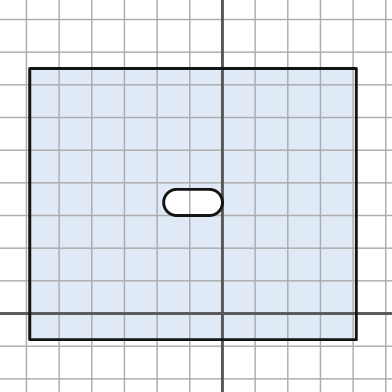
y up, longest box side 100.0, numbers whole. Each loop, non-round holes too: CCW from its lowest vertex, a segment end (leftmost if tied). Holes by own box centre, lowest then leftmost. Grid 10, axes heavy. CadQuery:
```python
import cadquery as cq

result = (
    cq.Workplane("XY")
    .moveTo(-59.0, -8.0)
    .lineTo(41.0, -8.0)
    .lineTo(41.0, 75.0)
    .lineTo(-59.0, 75.0)
    .close()
    .moveTo(-14.0, 30.0)
    .lineTo(-4.0, 30.0)
    .threePointArc((0.0, 34.0), (-4.0, 38.0))
    .lineTo(-14.0, 38.0)
    .threePointArc((-18.0, 34.0), (-14.0, 30.0))
    .close()
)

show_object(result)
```